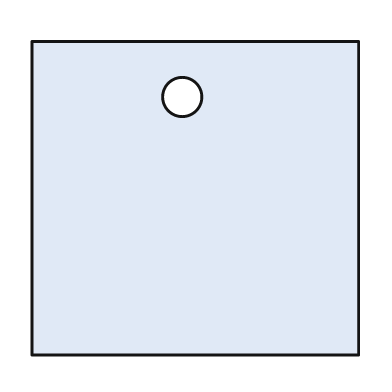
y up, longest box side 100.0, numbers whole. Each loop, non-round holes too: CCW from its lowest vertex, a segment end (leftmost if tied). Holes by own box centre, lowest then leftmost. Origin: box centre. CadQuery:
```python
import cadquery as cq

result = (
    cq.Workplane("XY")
    .moveTo(-50.0, -48.0)
    .lineTo(50.0, -48.0)
    .lineTo(50.0, 48.0)
    .lineTo(-50.0, 48.0)
    .close()
    .moveTo(-4.0, 31.0)
    .circle(6.0)
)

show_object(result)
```